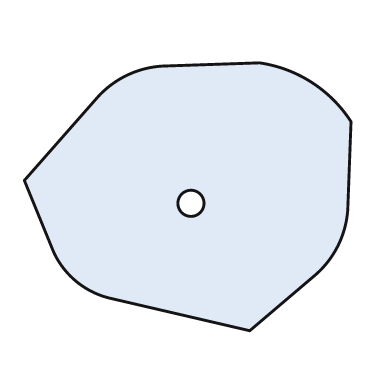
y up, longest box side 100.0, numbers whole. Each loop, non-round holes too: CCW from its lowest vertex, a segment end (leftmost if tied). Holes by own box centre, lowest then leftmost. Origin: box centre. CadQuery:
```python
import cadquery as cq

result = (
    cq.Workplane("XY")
    .moveTo(19.0, -41.0)
    .lineTo(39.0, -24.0)
    .threePointArc((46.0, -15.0), (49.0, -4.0))
    .lineTo(50.0, 23.0)
    .threePointArc((38.0, 35.0), (22.0, 41.0))
    .lineTo(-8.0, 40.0)
    .threePointArc((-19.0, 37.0), (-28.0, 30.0))
    .lineTo(-50.0, 5.0)
    .lineTo(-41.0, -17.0)
    .threePointArc((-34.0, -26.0), (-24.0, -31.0))
    .close()
    .moveTo(1.0, -2.0)
    .circle(4.0)
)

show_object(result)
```